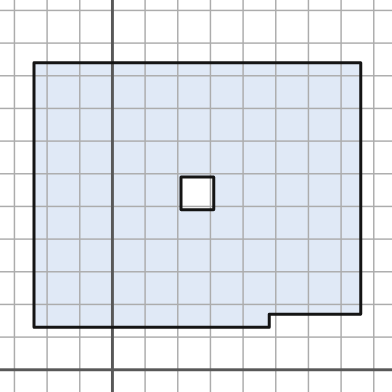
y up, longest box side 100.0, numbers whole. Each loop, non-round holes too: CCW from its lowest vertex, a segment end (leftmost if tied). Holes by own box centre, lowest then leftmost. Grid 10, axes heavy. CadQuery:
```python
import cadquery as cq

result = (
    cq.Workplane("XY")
    .moveTo(-24.0, 13.0)
    .lineTo(48.0, 13.0)
    .lineTo(48.0, 17.0)
    .lineTo(76.0, 17.0)
    .lineTo(76.0, 94.0)
    .lineTo(-24.0, 94.0)
    .close()
    .moveTo(21.0, 49.0)
    .lineTo(31.0, 49.0)
    .lineTo(31.0, 59.0)
    .lineTo(21.0, 59.0)
    .close()
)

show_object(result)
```